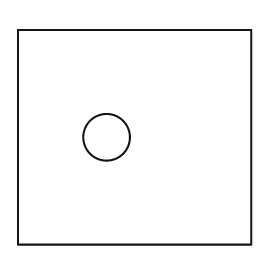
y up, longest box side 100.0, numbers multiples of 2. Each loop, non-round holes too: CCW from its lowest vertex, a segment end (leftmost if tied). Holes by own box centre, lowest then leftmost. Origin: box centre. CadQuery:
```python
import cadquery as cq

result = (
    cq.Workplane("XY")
    .moveTo(-50.0, -46.0)
    .lineTo(50.0, -46.0)
    .lineTo(50.0, 46.0)
    .lineTo(-50.0, 46.0)
    .close()
    .moveTo(-12.0, 0.0)
    .circle(10.0)
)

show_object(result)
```